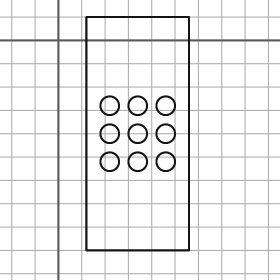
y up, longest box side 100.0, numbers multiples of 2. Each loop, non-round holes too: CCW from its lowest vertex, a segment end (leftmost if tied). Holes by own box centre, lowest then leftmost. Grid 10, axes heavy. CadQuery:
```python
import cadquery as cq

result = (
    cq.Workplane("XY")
    .moveTo(12.0, -90.0)
    .lineTo(56.0, -90.0)
    .lineTo(56.0, 10.0)
    .lineTo(12.0, 10.0)
    .close()
    .moveTo(22.0, -52.0)
    .circle(4.0)
    .moveTo(34.0, -52.0)
    .circle(4.0)
    .moveTo(46.0, -52.0)
    .circle(4.0)
    .moveTo(22.0, -40.0)
    .circle(4.0)
    .moveTo(34.0, -40.0)
    .circle(4.0)
    .moveTo(46.0, -40.0)
    .circle(4.0)
    .moveTo(22.0, -28.0)
    .circle(4.0)
    .moveTo(34.0, -28.0)
    .circle(4.0)
    .moveTo(46.0, -28.0)
    .circle(4.0)
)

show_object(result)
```